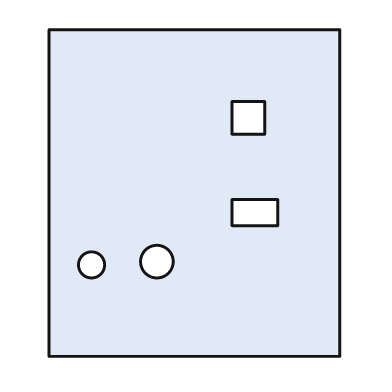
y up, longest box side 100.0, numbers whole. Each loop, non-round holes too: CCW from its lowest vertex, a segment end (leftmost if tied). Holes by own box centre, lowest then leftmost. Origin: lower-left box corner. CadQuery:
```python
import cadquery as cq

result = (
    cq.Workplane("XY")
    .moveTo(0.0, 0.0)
    .lineTo(89.0, 0.0)
    .lineTo(89.0, 100.0)
    .lineTo(0.0, 100.0)
    .close()
    .moveTo(13.0, 28.0)
    .circle(4.0)
    .moveTo(33.0, 29.0)
    .circle(5.0)
    .moveTo(56.0, 40.0)
    .lineTo(70.0, 40.0)
    .lineTo(70.0, 48.0)
    .lineTo(56.0, 48.0)
    .close()
    .moveTo(56.0, 68.0)
    .lineTo(66.0, 68.0)
    .lineTo(66.0, 78.0)
    .lineTo(56.0, 78.0)
    .close()
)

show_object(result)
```